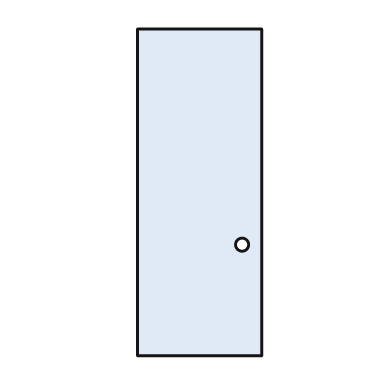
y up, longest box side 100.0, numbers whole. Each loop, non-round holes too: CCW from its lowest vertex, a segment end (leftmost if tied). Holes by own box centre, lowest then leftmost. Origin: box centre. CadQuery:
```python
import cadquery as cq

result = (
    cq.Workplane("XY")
    .moveTo(-19.0, -50.0)
    .lineTo(19.0, -50.0)
    .lineTo(19.0, 50.0)
    .lineTo(-19.0, 50.0)
    .close()
    .moveTo(13.0, -16.0)
    .circle(2.0)
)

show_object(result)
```